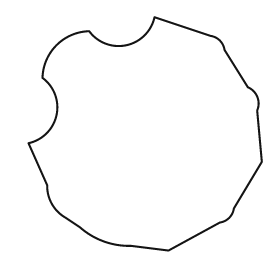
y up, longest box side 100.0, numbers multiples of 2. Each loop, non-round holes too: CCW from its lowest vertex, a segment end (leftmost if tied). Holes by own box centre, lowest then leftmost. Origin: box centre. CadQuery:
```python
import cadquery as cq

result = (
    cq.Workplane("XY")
    .moveTo(10.0, -50.0)
    .lineTo(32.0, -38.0)
    .threePointArc((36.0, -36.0), (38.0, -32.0))
    .lineTo(50.0, -12.0)
    .lineTo(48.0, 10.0)
    .threePointArc((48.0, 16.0), (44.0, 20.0))
    .lineTo(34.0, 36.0)
    .threePointArc((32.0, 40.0), (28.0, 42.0))
    .lineTo(4.0, 50.0)
    .threePointArc((-8.0, 38.0), (-24.0, 44.0))
    .threePointArc((-38.0, 38.0), (-44.0, 24.0))
    .threePointArc((-38.0, 8.0), (-50.0, -4.0))
    .lineTo(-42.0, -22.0)
    .threePointArc((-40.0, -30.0), (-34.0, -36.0))
    .lineTo(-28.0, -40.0)
    .threePointArc((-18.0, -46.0), (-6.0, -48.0))
    .close()
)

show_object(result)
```